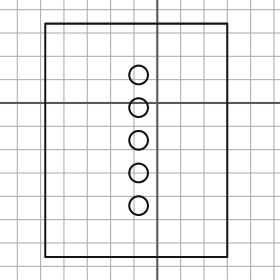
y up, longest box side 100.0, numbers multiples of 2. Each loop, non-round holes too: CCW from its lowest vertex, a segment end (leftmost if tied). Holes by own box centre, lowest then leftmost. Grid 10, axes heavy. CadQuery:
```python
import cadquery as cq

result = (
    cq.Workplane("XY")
    .moveTo(-48.0, -66.0)
    .lineTo(30.0, -66.0)
    .lineTo(30.0, 34.0)
    .lineTo(-48.0, 34.0)
    .close()
    .moveTo(-8.0, -44.0)
    .circle(4.0)
    .moveTo(-8.0, -30.0)
    .circle(4.0)
    .moveTo(-8.0, -16.0)
    .circle(4.0)
    .moveTo(-8.0, -2.0)
    .circle(4.0)
    .moveTo(-8.0, 12.0)
    .circle(4.0)
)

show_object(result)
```